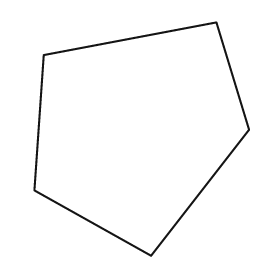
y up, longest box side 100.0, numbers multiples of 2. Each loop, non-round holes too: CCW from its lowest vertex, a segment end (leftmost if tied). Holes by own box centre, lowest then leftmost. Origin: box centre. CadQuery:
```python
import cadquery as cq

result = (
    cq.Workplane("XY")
    .moveTo(4.0, -50.0)
    .lineTo(46.0, 4.0)
    .lineTo(32.0, 50.0)
    .lineTo(-42.0, 36.0)
    .lineTo(-46.0, -22.0)
    .close()
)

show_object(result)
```